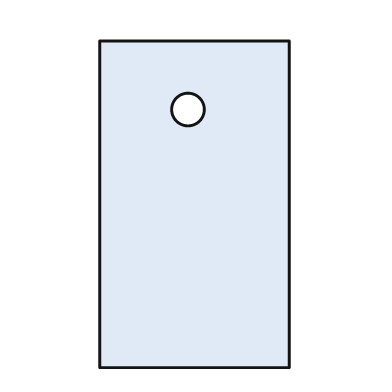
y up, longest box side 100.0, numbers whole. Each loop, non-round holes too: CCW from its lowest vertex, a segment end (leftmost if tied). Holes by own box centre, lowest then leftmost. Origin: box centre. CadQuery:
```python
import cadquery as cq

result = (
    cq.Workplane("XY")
    .moveTo(-29.0, -50.0)
    .lineTo(29.0, -50.0)
    .lineTo(29.0, 50.0)
    .lineTo(-29.0, 50.0)
    .close()
    .moveTo(-2.0, 29.0)
    .circle(5.0)
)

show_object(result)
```